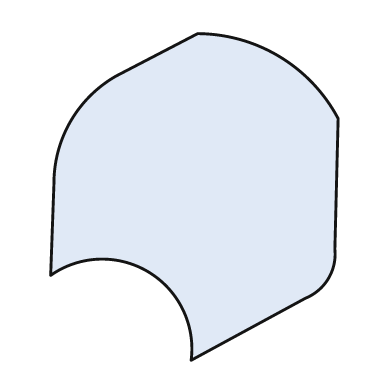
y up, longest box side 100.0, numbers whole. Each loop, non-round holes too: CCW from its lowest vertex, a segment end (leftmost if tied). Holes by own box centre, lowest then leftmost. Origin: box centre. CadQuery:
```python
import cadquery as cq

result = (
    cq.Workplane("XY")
    .moveTo(-1.0, -50.0)
    .lineTo(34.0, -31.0)
    .threePointArc((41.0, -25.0), (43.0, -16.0))
    .lineTo(44.0, 24.0)
    .threePointArc((26.0, 43.0), (1.0, 50.0))
    .lineTo(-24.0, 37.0)
    .threePointArc((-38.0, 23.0), (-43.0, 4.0))
    .lineTo(-44.0, -24.0)
    .threePointArc((-14.0, -23.0), (-1.0, -50.0))
    .close()
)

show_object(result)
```